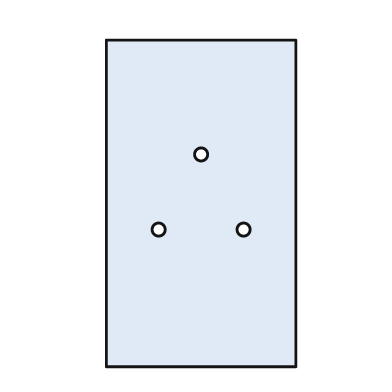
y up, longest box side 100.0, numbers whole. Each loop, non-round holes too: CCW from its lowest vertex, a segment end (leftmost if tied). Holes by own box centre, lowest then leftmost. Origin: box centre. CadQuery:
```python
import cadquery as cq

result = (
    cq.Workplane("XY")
    .moveTo(-29.0, -50.0)
    .lineTo(29.0, -50.0)
    .lineTo(29.0, 50.0)
    .lineTo(-29.0, 50.0)
    .close()
    .moveTo(-13.0, -8.0)
    .circle(2.0)
    .moveTo(13.0, -8.0)
    .circle(2.0)
    .moveTo(0.0, 15.0)
    .circle(2.0)
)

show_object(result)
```